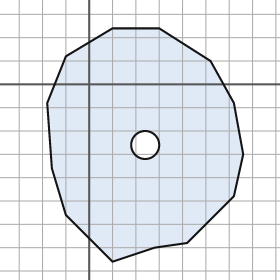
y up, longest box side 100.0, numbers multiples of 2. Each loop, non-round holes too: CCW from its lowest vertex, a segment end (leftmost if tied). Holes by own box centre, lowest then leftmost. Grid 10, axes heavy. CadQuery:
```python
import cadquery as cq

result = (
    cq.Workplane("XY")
    .moveTo(10.0, -76.0)
    .lineTo(28.0, -70.0)
    .lineTo(42.0, -68.0)
    .lineTo(62.0, -48.0)
    .lineTo(66.0, -30.0)
    .lineTo(62.0, -8.0)
    .lineTo(52.0, 10.0)
    .lineTo(30.0, 24.0)
    .lineTo(10.0, 24.0)
    .lineTo(-10.0, 12.0)
    .lineTo(-18.0, -8.0)
    .lineTo(-16.0, -36.0)
    .lineTo(-10.0, -56.0)
    .close()
    .moveTo(24.0, -26.0)
    .circle(6.0)
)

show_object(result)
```